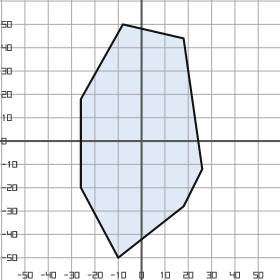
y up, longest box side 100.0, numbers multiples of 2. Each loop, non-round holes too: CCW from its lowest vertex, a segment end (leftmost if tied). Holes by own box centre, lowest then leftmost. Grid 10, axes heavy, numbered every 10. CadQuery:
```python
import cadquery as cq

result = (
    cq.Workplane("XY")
    .moveTo(-10.0, -50.0)
    .lineTo(18.0, -28.0)
    .lineTo(26.0, -12.0)
    .lineTo(18.0, 44.0)
    .lineTo(-8.0, 50.0)
    .lineTo(-26.0, 18.0)
    .lineTo(-26.0, -20.0)
    .close()
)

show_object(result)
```